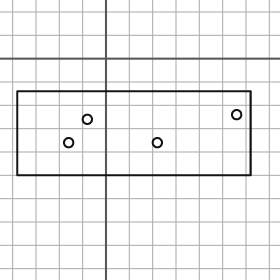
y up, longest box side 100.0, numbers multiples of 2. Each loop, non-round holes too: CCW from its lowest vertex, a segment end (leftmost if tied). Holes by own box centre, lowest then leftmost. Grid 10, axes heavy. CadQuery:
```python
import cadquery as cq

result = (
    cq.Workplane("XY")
    .moveTo(-38.0, -50.0)
    .lineTo(62.0, -50.0)
    .lineTo(62.0, -14.0)
    .lineTo(-38.0, -14.0)
    .close()
    .moveTo(-16.0, -36.0)
    .circle(2.0)
    .moveTo(22.0, -36.0)
    .circle(2.0)
    .moveTo(-8.0, -26.0)
    .circle(2.0)
    .moveTo(56.0, -24.0)
    .circle(2.0)
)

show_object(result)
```